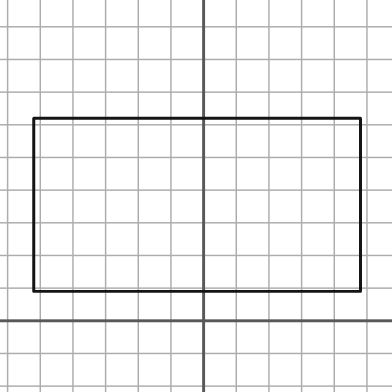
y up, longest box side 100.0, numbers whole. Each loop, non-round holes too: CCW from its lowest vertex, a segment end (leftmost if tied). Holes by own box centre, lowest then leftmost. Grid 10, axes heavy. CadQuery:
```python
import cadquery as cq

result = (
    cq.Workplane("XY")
    .moveTo(-52.0, 9.0)
    .lineTo(48.0, 9.0)
    .lineTo(48.0, 62.0)
    .lineTo(-52.0, 62.0)
    .close()
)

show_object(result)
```